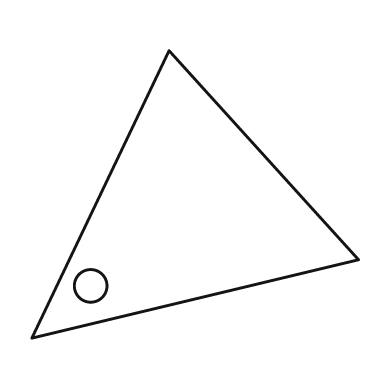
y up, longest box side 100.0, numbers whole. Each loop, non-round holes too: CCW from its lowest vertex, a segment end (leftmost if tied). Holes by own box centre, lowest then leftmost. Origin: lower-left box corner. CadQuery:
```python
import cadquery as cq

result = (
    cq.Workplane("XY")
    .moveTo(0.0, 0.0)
    .lineTo(100.0, 24.0)
    .lineTo(42.0, 88.0)
    .close()
    .moveTo(18.0, 16.0)
    .circle(5.0)
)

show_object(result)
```